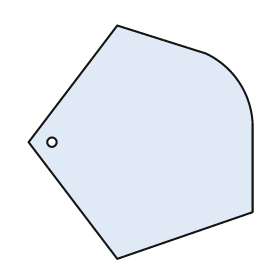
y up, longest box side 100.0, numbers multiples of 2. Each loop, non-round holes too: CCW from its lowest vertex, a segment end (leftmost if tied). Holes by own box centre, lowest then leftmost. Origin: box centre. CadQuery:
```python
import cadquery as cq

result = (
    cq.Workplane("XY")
    .moveTo(-10.0, -50.0)
    .lineTo(48.0, -30.0)
    .lineTo(48.0, 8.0)
    .threePointArc((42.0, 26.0), (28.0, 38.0))
    .lineTo(-10.0, 50.0)
    .lineTo(-48.0, 0.0)
    .close()
    .moveTo(-38.0, 0.0)
    .circle(2.0)
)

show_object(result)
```